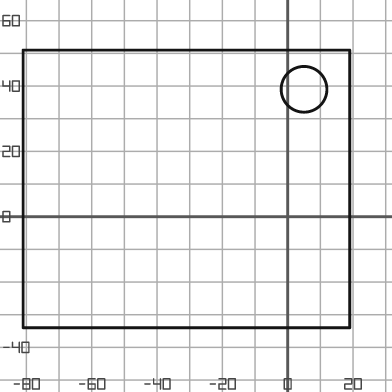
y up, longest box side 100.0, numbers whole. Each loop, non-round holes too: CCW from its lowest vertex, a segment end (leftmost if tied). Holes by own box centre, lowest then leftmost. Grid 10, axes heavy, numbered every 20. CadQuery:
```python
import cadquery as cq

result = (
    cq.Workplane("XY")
    .moveTo(-81.0, -34.0)
    .lineTo(19.0, -34.0)
    .lineTo(19.0, 51.0)
    .lineTo(-81.0, 51.0)
    .close()
    .moveTo(5.0, 39.0)
    .circle(7.0)
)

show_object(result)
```